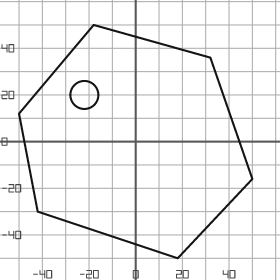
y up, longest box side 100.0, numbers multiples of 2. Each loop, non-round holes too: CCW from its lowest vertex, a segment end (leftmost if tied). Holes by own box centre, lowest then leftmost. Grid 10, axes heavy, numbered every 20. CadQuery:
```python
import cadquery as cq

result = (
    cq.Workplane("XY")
    .moveTo(18.0, -50.0)
    .lineTo(50.0, -16.0)
    .lineTo(32.0, 36.0)
    .lineTo(-18.0, 50.0)
    .lineTo(-50.0, 12.0)
    .lineTo(-42.0, -30.0)
    .close()
    .moveTo(-22.0, 20.0)
    .circle(6.0)
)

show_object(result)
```